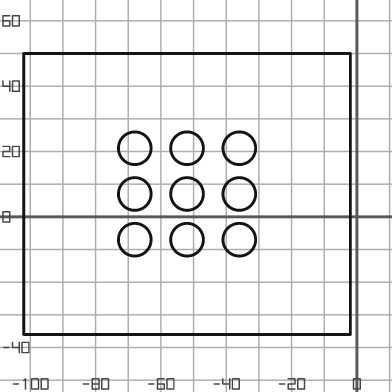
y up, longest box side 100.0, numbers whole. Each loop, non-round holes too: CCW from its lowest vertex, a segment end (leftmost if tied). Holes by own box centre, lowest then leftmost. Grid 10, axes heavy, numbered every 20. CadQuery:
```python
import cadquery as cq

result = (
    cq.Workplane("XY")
    .moveTo(-102.0, -36.0)
    .lineTo(-2.0, -36.0)
    .lineTo(-2.0, 50.0)
    .lineTo(-102.0, 50.0)
    .close()
    .moveTo(-68.0, -7.0)
    .circle(5.0)
    .moveTo(-52.0, -7.0)
    .circle(5.0)
    .moveTo(-36.0, -7.0)
    .circle(5.0)
    .moveTo(-68.0, 7.0)
    .circle(5.0)
    .moveTo(-52.0, 7.0)
    .circle(5.0)
    .moveTo(-36.0, 7.0)
    .circle(5.0)
    .moveTo(-68.0, 21.0)
    .circle(5.0)
    .moveTo(-52.0, 21.0)
    .circle(5.0)
    .moveTo(-36.0, 21.0)
    .circle(5.0)
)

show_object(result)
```